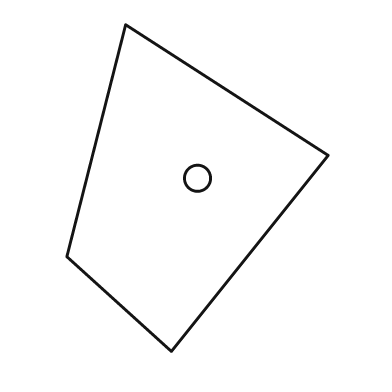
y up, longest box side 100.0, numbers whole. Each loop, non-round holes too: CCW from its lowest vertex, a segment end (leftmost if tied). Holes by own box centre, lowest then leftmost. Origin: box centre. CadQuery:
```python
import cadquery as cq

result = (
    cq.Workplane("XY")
    .moveTo(-8.0, -50.0)
    .lineTo(40.0, 10.0)
    .lineTo(-22.0, 50.0)
    .lineTo(-40.0, -21.0)
    .close()
    .moveTo(0.0, 3.0)
    .circle(4.0)
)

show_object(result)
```